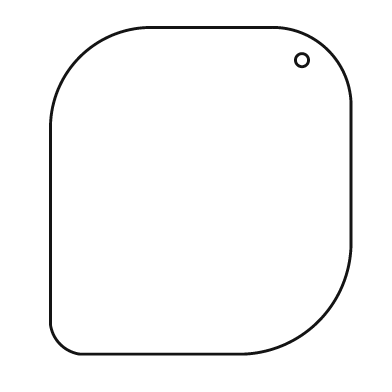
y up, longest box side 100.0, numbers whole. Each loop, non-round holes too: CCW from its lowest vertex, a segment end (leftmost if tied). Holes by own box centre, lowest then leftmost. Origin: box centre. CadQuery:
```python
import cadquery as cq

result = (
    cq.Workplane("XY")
    .moveTo(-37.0, -50.0)
    .lineTo(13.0, -50.0)
    .threePointArc((36.0, -40.0), (46.0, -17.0))
    .lineTo(46.0, 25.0)
    .threePointArc((39.0, 43.0), (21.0, 50.0))
    .lineTo(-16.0, 50.0)
    .threePointArc((-37.0, 41.0), (-46.0, 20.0))
    .lineTo(-46.0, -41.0)
    .threePointArc((-43.0, -47.0), (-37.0, -50.0))
    .close()
    .moveTo(31.0, 40.0)
    .circle(2.0)
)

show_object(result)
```